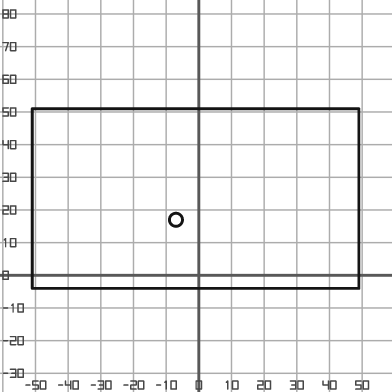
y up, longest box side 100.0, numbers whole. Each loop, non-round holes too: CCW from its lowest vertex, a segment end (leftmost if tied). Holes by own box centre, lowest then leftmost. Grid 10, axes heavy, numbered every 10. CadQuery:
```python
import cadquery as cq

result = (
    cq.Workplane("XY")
    .moveTo(-51.0, -4.0)
    .lineTo(49.0, -4.0)
    .lineTo(49.0, 51.0)
    .lineTo(-51.0, 51.0)
    .close()
    .moveTo(-7.0, 17.0)
    .circle(2.0)
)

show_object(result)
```